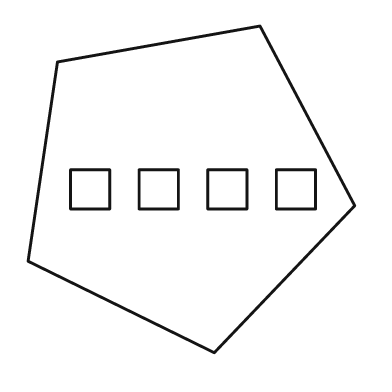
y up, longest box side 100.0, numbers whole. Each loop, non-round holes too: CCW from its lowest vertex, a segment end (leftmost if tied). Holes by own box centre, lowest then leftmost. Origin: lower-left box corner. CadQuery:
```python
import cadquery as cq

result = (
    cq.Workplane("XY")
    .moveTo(57.0, 0.0)
    .lineTo(100.0, 45.0)
    .lineTo(71.0, 100.0)
    .lineTo(9.0, 89.0)
    .lineTo(0.0, 28.0)
    .close()
    .moveTo(13.0, 44.0)
    .lineTo(25.0, 44.0)
    .lineTo(25.0, 56.0)
    .lineTo(13.0, 56.0)
    .close()
    .moveTo(34.0, 44.0)
    .lineTo(46.0, 44.0)
    .lineTo(46.0, 56.0)
    .lineTo(34.0, 56.0)
    .close()
    .moveTo(55.0, 44.0)
    .lineTo(67.0, 44.0)
    .lineTo(67.0, 56.0)
    .lineTo(55.0, 56.0)
    .close()
    .moveTo(76.0, 44.0)
    .lineTo(88.0, 44.0)
    .lineTo(88.0, 56.0)
    .lineTo(76.0, 56.0)
    .close()
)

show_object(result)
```